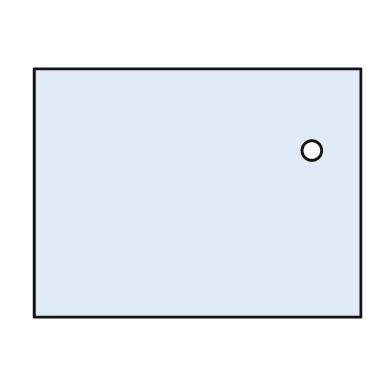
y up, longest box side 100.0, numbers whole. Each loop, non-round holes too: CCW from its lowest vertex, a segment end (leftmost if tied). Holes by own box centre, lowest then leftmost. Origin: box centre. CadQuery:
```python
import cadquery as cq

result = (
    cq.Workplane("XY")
    .moveTo(-50.0, -38.0)
    .lineTo(50.0, -38.0)
    .lineTo(50.0, 38.0)
    .lineTo(-50.0, 38.0)
    .close()
    .moveTo(35.0, 13.0)
    .circle(3.0)
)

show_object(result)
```